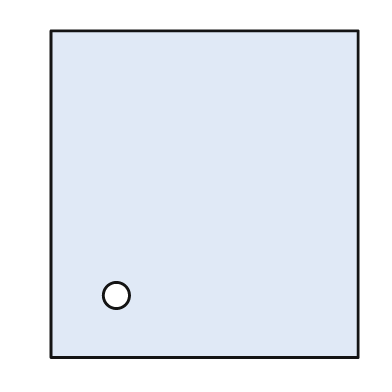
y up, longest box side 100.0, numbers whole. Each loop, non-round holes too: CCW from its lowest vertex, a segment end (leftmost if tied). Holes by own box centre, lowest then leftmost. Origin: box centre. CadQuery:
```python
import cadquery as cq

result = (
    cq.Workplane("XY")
    .moveTo(-47.0, -50.0)
    .lineTo(47.0, -50.0)
    .lineTo(47.0, 50.0)
    .lineTo(-47.0, 50.0)
    .close()
    .moveTo(-27.0, -31.0)
    .circle(4.0)
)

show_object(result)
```